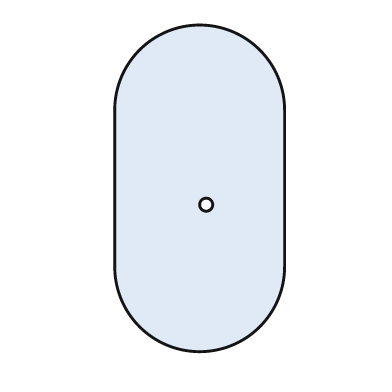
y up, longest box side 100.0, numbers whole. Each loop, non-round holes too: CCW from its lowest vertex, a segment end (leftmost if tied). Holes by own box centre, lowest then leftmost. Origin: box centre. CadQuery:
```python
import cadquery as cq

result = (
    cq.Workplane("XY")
    .moveTo(-26.0, -24.0)
    .threePointArc((0.0, -50.0), (26.0, -24.0))
    .lineTo(26.0, 24.0)
    .threePointArc((0.0, 50.0), (-26.0, 24.0))
    .close()
    .moveTo(2.0, -5.0)
    .circle(2.0)
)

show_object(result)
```